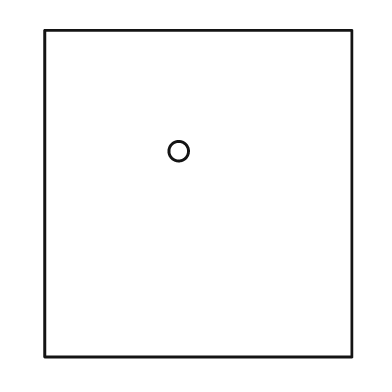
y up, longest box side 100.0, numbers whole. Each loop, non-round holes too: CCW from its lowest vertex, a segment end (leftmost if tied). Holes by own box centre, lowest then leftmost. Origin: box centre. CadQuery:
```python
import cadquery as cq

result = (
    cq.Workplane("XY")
    .moveTo(-47.0, -50.0)
    .lineTo(47.0, -50.0)
    .lineTo(47.0, 50.0)
    .lineTo(-47.0, 50.0)
    .close()
    .moveTo(-6.0, 13.0)
    .circle(3.0)
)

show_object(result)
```